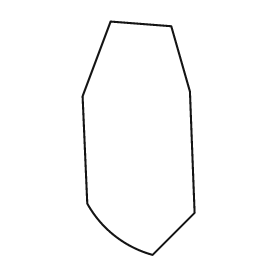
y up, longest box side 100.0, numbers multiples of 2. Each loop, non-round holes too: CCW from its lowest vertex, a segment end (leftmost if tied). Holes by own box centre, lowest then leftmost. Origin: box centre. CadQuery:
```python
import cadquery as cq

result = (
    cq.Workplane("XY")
    .moveTo(6.0, -50.0)
    .lineTo(24.0, -32.0)
    .lineTo(22.0, 20.0)
    .lineTo(14.0, 48.0)
    .lineTo(-12.0, 50.0)
    .lineTo(-24.0, 18.0)
    .lineTo(-22.0, -28.0)
    .threePointArc((-10.0, -42.0), (6.0, -50.0))
    .close()
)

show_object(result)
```